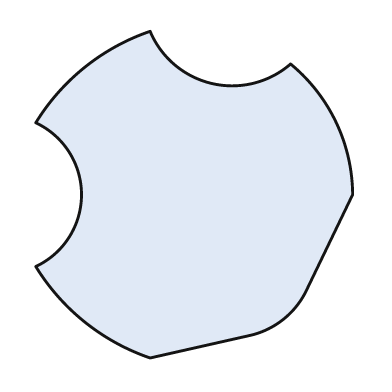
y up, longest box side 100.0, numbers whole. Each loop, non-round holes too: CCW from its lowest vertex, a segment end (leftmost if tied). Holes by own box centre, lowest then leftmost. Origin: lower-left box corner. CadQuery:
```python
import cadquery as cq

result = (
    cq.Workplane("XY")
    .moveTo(35.0, 0.0)
    .lineTo(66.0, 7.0)
    .threePointArc((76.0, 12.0), (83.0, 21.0))
    .lineTo(97.0, 50.0)
    .threePointArc((92.0, 72.0), (78.0, 90.0))
    .threePointArc((54.0, 84.0), (35.0, 100.0))
    .threePointArc((15.0, 89.0), (0.0, 72.0))
    .threePointArc((14.0, 50.0), (0.0, 28.0))
    .threePointArc((15.0, 11.0), (35.0, 0.0))
    .close()
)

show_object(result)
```